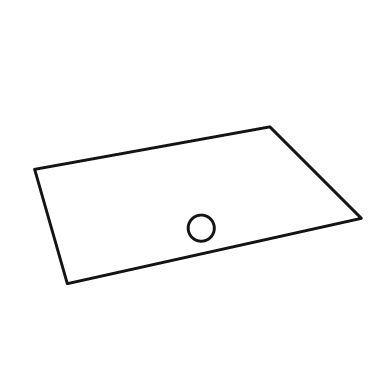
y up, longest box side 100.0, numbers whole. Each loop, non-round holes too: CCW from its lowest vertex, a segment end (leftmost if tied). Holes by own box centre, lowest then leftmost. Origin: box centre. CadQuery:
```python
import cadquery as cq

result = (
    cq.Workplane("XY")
    .moveTo(-40.0, -24.0)
    .lineTo(50.0, -4.0)
    .lineTo(22.0, 24.0)
    .lineTo(-50.0, 11.0)
    .close()
    .moveTo(1.0, -7.0)
    .circle(4.0)
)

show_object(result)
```